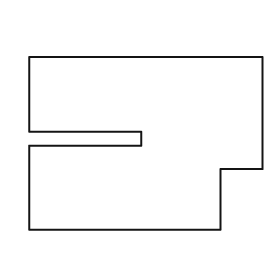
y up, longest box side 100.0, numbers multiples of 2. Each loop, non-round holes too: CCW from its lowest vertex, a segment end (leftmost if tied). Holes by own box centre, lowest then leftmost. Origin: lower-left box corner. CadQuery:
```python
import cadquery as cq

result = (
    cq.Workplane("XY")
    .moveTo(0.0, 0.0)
    .lineTo(82.0, 0.0)
    .lineTo(82.0, 26.0)
    .lineTo(100.0, 26.0)
    .lineTo(100.0, 74.0)
    .lineTo(0.0, 74.0)
    .lineTo(0.0, 42.0)
    .lineTo(48.0, 42.0)
    .lineTo(48.0, 36.0)
    .lineTo(0.0, 36.0)
    .close()
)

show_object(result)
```